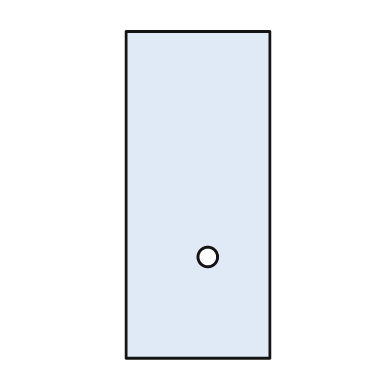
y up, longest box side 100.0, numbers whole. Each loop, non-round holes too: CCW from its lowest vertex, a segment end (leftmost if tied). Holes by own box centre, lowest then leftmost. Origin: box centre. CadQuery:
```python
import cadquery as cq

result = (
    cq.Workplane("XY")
    .moveTo(-22.0, -50.0)
    .lineTo(22.0, -50.0)
    .lineTo(22.0, 50.0)
    .lineTo(-22.0, 50.0)
    .close()
    .moveTo(3.0, -19.0)
    .circle(3.0)
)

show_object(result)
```